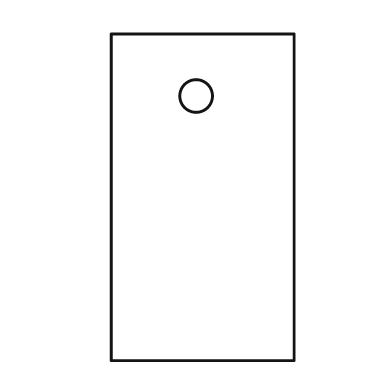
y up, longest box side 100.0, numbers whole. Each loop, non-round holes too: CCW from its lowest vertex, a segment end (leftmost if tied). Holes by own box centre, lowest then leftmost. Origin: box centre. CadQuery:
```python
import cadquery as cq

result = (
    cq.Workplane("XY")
    .moveTo(-28.0, -50.0)
    .lineTo(28.0, -50.0)
    .lineTo(28.0, 50.0)
    .lineTo(-28.0, 50.0)
    .close()
    .moveTo(-2.0, 31.0)
    .circle(5.0)
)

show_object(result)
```